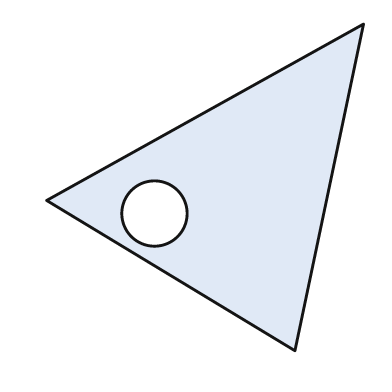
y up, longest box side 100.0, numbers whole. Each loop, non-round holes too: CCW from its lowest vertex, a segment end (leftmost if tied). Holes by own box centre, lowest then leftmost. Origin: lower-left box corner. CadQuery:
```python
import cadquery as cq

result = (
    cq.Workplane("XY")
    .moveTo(76.0, 0.0)
    .lineTo(97.0, 100.0)
    .lineTo(0.0, 46.0)
    .close()
    .moveTo(33.0, 42.0)
    .circle(10.0)
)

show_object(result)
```